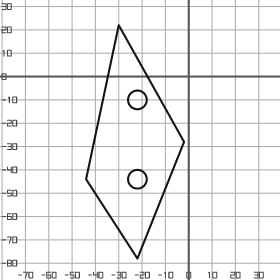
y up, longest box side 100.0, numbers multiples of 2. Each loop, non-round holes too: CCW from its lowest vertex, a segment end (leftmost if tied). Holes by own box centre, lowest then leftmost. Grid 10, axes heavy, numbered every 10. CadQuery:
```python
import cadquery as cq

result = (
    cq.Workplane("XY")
    .moveTo(-22.0, -78.0)
    .lineTo(-2.0, -28.0)
    .lineTo(-30.0, 22.0)
    .lineTo(-44.0, -44.0)
    .close()
    .moveTo(-22.0, -44.0)
    .circle(4.0)
    .moveTo(-22.0, -10.0)
    .circle(4.0)
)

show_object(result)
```